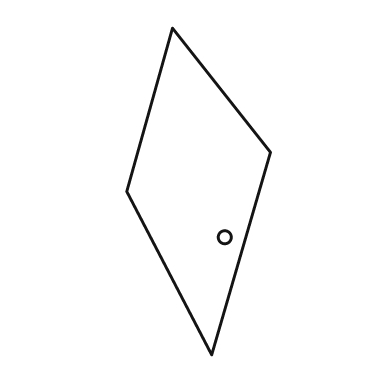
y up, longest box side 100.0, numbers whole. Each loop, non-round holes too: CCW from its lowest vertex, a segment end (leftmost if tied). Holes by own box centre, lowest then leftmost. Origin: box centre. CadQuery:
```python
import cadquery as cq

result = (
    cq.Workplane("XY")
    .moveTo(4.0, -50.0)
    .lineTo(22.0, 12.0)
    .lineTo(-8.0, 50.0)
    .lineTo(-22.0, 0.0)
    .close()
    .moveTo(8.0, -14.0)
    .circle(2.0)
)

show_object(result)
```